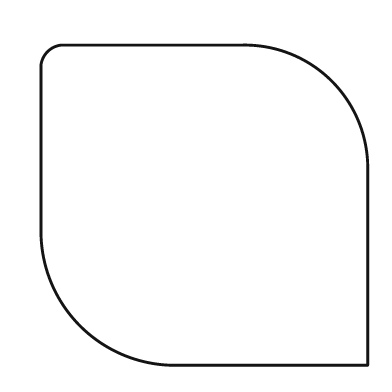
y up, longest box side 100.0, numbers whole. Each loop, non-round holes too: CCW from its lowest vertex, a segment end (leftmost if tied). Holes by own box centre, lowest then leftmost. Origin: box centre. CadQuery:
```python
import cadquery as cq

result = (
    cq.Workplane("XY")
    .moveTo(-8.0, -49.0)
    .lineTo(50.0, -49.0)
    .lineTo(50.0, 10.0)
    .threePointArc((39.0, 38.0), (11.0, 49.0))
    .lineTo(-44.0, 49.0)
    .threePointArc((-48.0, 47.0), (-50.0, 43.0))
    .lineTo(-50.0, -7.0)
    .threePointArc((-38.0, -37.0), (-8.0, -49.0))
    .close()
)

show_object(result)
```